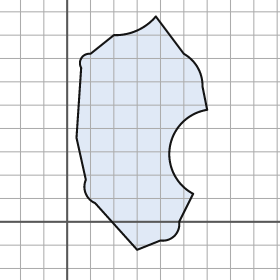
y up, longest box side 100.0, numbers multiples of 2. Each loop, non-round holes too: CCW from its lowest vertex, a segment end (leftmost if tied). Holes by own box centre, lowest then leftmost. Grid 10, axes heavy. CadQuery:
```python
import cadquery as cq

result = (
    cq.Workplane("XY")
    .moveTo(30.0, -12.0)
    .lineTo(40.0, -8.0)
    .threePointArc((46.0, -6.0), (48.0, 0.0))
    .lineTo(54.0, 12.0)
    .threePointArc((44.0, 32.0), (60.0, 48.0))
    .lineTo(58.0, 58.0)
    .threePointArc((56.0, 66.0), (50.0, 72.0))
    .lineTo(38.0, 88.0)
    .threePointArc((30.0, 82.0), (20.0, 80.0))
    .lineTo(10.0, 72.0)
    .threePointArc((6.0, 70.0), (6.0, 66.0))
    .lineTo(4.0, 36.0)
    .lineTo(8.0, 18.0)
    .threePointArc((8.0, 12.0), (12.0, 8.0))
    .close()
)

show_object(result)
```